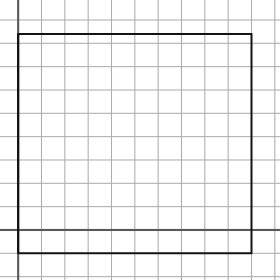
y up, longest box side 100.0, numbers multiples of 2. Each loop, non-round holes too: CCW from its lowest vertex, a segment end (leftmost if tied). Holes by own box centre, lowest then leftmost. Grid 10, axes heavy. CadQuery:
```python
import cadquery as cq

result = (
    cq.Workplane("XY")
    .moveTo(0.0, -10.0)
    .lineTo(100.0, -10.0)
    .lineTo(100.0, 84.0)
    .lineTo(0.0, 84.0)
    .close()
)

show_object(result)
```